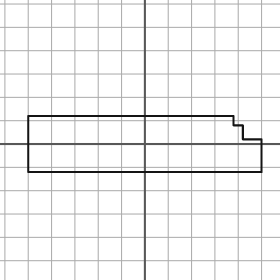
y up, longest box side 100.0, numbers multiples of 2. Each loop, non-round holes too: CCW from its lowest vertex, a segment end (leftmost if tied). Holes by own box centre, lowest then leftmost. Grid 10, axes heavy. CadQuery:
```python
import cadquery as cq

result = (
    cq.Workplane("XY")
    .moveTo(-50.0, -12.0)
    .lineTo(50.0, -12.0)
    .lineTo(50.0, 2.0)
    .lineTo(42.0, 2.0)
    .lineTo(42.0, 8.0)
    .lineTo(38.0, 8.0)
    .lineTo(38.0, 12.0)
    .lineTo(-50.0, 12.0)
    .close()
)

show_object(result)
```